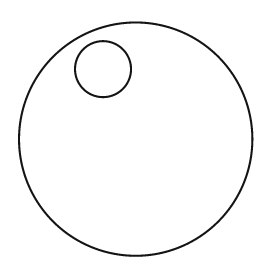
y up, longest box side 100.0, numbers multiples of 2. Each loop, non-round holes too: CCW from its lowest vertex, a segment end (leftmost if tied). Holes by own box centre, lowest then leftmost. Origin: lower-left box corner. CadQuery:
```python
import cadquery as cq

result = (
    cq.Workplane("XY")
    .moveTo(50.0, 50.0)
    .circle(50.0)
    .moveTo(36.0, 80.0)
    .circle(12.0)
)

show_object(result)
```